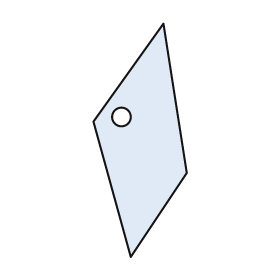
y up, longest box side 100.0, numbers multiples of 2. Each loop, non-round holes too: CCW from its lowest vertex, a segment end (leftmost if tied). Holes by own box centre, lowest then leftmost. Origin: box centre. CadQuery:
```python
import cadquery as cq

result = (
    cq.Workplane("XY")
    .moveTo(-4.0, -50.0)
    .lineTo(20.0, -14.0)
    .lineTo(10.0, 50.0)
    .lineTo(-20.0, 8.0)
    .close()
    .moveTo(-8.0, 10.0)
    .circle(4.0)
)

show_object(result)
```